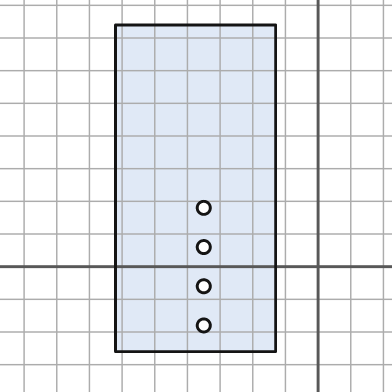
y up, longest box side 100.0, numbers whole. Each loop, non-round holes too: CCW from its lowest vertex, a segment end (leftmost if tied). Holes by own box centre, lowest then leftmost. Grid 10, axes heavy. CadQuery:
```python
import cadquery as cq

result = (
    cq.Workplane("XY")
    .moveTo(-62.0, -26.0)
    .lineTo(-13.0, -26.0)
    .lineTo(-13.0, 74.0)
    .lineTo(-62.0, 74.0)
    .close()
    .moveTo(-35.0, -18.0)
    .circle(2.0)
    .moveTo(-35.0, -6.0)
    .circle(2.0)
    .moveTo(-35.0, 6.0)
    .circle(2.0)
    .moveTo(-35.0, 18.0)
    .circle(2.0)
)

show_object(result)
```